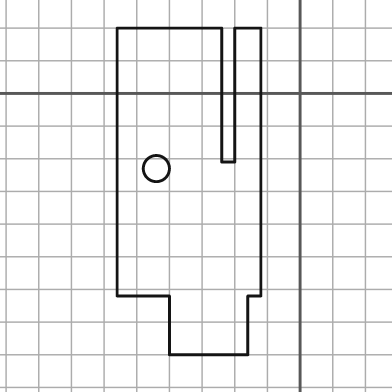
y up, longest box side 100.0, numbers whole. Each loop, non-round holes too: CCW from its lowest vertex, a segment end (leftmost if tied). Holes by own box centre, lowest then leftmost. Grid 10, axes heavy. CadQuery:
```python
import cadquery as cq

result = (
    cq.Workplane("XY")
    .moveTo(-40.0, -80.0)
    .lineTo(-16.0, -80.0)
    .lineTo(-16.0, -62.0)
    .lineTo(-12.0, -62.0)
    .lineTo(-12.0, 20.0)
    .lineTo(-20.0, 20.0)
    .lineTo(-20.0, -21.0)
    .lineTo(-24.0, -21.0)
    .lineTo(-24.0, 20.0)
    .lineTo(-56.0, 20.0)
    .lineTo(-56.0, -62.0)
    .lineTo(-40.0, -62.0)
    .close()
    .moveTo(-44.0, -23.0)
    .circle(4.0)
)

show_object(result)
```